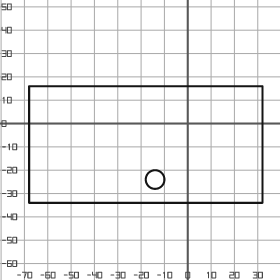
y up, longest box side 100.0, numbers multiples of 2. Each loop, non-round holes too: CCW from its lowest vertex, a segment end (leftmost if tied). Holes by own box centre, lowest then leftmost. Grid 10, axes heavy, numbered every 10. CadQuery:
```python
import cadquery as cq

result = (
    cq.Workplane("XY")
    .moveTo(-68.0, -34.0)
    .lineTo(32.0, -34.0)
    .lineTo(32.0, 16.0)
    .lineTo(-68.0, 16.0)
    .close()
    .moveTo(-14.0, -24.0)
    .circle(4.0)
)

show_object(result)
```